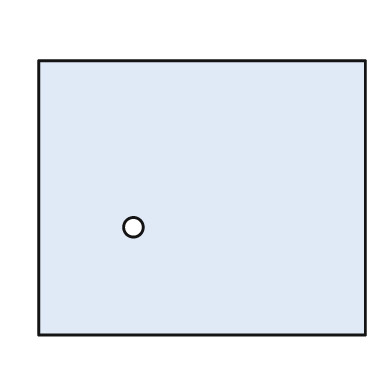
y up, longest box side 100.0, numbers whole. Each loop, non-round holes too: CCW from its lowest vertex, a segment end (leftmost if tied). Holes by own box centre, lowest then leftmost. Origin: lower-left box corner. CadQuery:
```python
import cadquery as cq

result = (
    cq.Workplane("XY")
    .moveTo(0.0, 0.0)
    .lineTo(100.0, 0.0)
    .lineTo(100.0, 84.0)
    .lineTo(0.0, 84.0)
    .close()
    .moveTo(29.0, 33.0)
    .circle(3.0)
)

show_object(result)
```